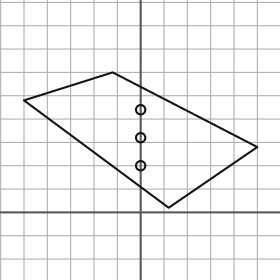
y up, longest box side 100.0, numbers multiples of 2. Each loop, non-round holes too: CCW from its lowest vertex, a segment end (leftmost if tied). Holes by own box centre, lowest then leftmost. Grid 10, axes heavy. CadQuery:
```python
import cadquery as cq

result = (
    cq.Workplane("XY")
    .moveTo(12.0, 2.0)
    .lineTo(50.0, 28.0)
    .lineTo(-12.0, 60.0)
    .lineTo(-50.0, 48.0)
    .close()
    .moveTo(0.0, 20.0)
    .circle(2.0)
    .moveTo(0.0, 32.0)
    .circle(2.0)
    .moveTo(0.0, 44.0)
    .circle(2.0)
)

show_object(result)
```